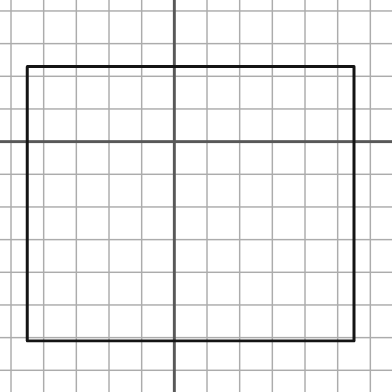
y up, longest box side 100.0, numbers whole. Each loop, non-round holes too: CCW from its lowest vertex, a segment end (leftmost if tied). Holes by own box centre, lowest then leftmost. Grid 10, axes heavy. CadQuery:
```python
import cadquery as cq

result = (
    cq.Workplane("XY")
    .moveTo(-45.0, -61.0)
    .lineTo(55.0, -61.0)
    .lineTo(55.0, 23.0)
    .lineTo(-45.0, 23.0)
    .close()
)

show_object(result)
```